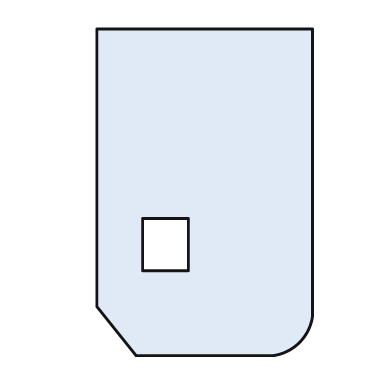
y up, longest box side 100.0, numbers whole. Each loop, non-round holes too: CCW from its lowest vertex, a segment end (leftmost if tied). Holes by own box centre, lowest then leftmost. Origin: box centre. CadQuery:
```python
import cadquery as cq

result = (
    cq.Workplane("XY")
    .moveTo(-21.0, -50.0)
    .lineTo(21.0, -50.0)
    .threePointArc((29.0, -46.0), (33.0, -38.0))
    .lineTo(33.0, 50.0)
    .lineTo(-33.0, 50.0)
    .lineTo(-33.0, -35.0)
    .close()
    .moveTo(-19.0, -24.0)
    .lineTo(-5.0, -24.0)
    .lineTo(-5.0, -8.0)
    .lineTo(-19.0, -8.0)
    .close()
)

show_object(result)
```